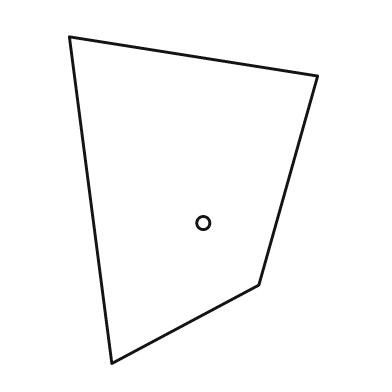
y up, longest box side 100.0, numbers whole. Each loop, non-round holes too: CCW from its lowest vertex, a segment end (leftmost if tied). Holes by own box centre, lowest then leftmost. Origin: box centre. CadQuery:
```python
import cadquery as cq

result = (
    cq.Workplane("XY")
    .moveTo(-25.0, -50.0)
    .lineTo(20.0, -26.0)
    .lineTo(38.0, 38.0)
    .lineTo(-38.0, 50.0)
    .close()
    .moveTo(3.0, -7.0)
    .circle(2.0)
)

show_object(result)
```